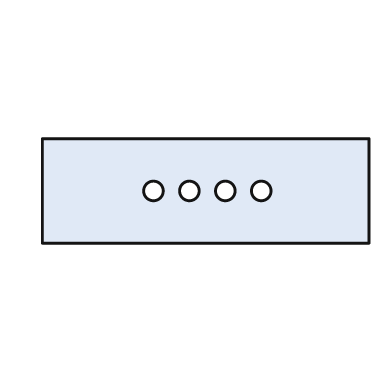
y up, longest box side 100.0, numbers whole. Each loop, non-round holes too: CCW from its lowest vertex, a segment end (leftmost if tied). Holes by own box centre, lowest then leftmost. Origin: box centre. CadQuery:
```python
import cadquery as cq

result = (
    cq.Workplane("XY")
    .moveTo(-50.0, -16.0)
    .lineTo(50.0, -16.0)
    .lineTo(50.0, 16.0)
    .lineTo(-50.0, 16.0)
    .close()
    .moveTo(-16.0, 0.0)
    .circle(3.0)
    .moveTo(-5.0, 0.0)
    .circle(3.0)
    .moveTo(6.0, 0.0)
    .circle(3.0)
    .moveTo(17.0, 0.0)
    .circle(3.0)
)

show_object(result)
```